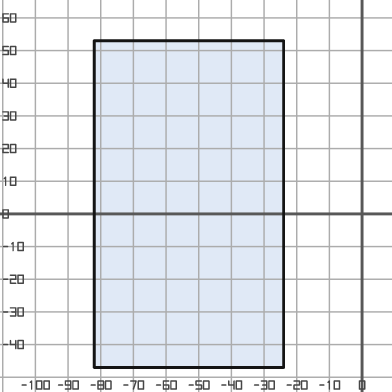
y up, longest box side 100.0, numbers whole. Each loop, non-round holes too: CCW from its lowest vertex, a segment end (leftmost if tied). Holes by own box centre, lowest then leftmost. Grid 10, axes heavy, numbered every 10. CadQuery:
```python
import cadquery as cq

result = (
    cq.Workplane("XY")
    .moveTo(-82.0, -47.0)
    .lineTo(-24.0, -47.0)
    .lineTo(-24.0, 53.0)
    .lineTo(-82.0, 53.0)
    .close()
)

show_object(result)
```